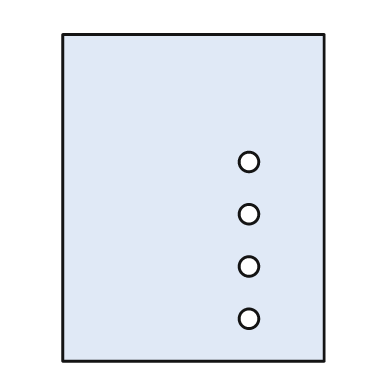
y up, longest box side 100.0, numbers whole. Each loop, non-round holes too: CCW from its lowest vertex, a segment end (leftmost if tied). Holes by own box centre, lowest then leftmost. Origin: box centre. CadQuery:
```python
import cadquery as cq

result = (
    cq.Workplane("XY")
    .moveTo(-40.0, -50.0)
    .lineTo(40.0, -50.0)
    .lineTo(40.0, 50.0)
    .lineTo(-40.0, 50.0)
    .close()
    .moveTo(17.0, -37.0)
    .circle(3.0)
    .moveTo(17.0, -21.0)
    .circle(3.0)
    .moveTo(17.0, -5.0)
    .circle(3.0)
    .moveTo(17.0, 11.0)
    .circle(3.0)
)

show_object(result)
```